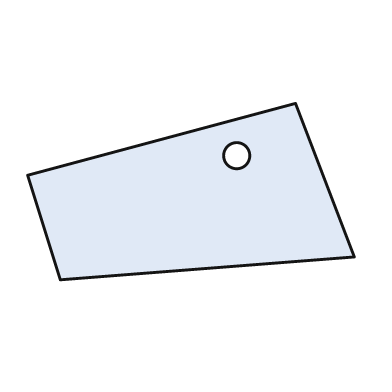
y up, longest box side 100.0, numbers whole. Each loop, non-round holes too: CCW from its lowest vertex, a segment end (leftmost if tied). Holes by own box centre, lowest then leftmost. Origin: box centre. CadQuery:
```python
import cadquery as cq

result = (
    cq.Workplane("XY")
    .moveTo(-40.0, -27.0)
    .lineTo(50.0, -20.0)
    .lineTo(32.0, 27.0)
    .lineTo(-50.0, 5.0)
    .close()
    .moveTo(14.0, 11.0)
    .circle(4.0)
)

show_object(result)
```